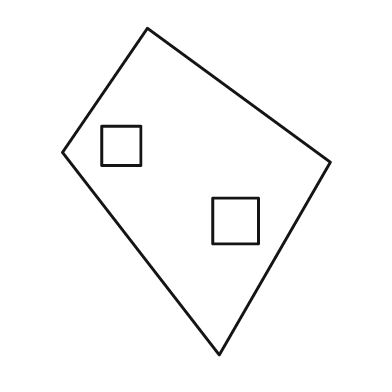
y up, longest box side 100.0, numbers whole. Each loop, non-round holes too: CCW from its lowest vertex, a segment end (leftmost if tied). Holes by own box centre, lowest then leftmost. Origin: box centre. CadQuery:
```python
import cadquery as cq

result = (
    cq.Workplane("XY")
    .moveTo(7.0, -50.0)
    .lineTo(41.0, 9.0)
    .lineTo(-15.0, 50.0)
    .lineTo(-41.0, 12.0)
    .close()
    .moveTo(5.0, -16.0)
    .lineTo(19.0, -16.0)
    .lineTo(19.0, -2.0)
    .lineTo(5.0, -2.0)
    .close()
    .moveTo(-29.0, 8.0)
    .lineTo(-17.0, 8.0)
    .lineTo(-17.0, 20.0)
    .lineTo(-29.0, 20.0)
    .close()
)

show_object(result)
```